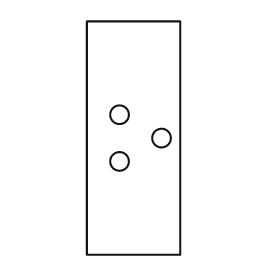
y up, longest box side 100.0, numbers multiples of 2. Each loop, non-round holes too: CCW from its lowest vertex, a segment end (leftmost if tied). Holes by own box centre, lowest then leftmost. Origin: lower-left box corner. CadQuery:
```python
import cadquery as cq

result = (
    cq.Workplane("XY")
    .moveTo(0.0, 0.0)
    .lineTo(40.0, 0.0)
    .lineTo(40.0, 100.0)
    .lineTo(0.0, 100.0)
    .close()
    .moveTo(14.0, 40.0)
    .circle(4.0)
    .moveTo(32.0, 50.0)
    .circle(4.0)
    .moveTo(14.0, 60.0)
    .circle(4.0)
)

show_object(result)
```